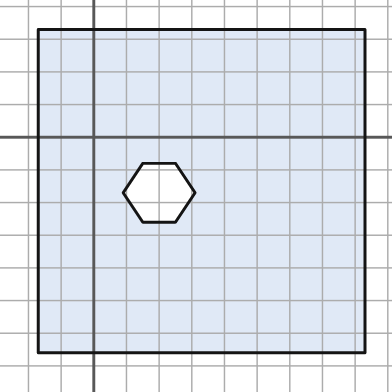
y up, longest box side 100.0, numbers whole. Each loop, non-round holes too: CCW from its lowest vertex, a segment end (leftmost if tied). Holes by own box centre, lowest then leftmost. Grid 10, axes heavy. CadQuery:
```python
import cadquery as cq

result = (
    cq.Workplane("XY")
    .moveTo(-17.0, -66.0)
    .lineTo(83.0, -66.0)
    .lineTo(83.0, 33.0)
    .lineTo(-17.0, 33.0)
    .close()
    .moveTo(15.0, -26.0)
    .lineTo(25.0, -26.0)
    .lineTo(31.0, -17.0)
    .lineTo(25.0, -8.0)
    .lineTo(15.0, -8.0)
    .lineTo(9.0, -17.0)
    .close()
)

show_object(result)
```